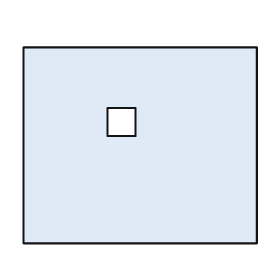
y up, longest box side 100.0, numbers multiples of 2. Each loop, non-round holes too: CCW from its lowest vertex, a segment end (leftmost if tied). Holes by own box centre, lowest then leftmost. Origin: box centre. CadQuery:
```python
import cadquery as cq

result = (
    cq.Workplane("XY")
    .moveTo(-50.0, -42.0)
    .lineTo(50.0, -42.0)
    .lineTo(50.0, 42.0)
    .lineTo(-50.0, 42.0)
    .close()
    .moveTo(-14.0, 4.0)
    .lineTo(-2.0, 4.0)
    .lineTo(-2.0, 16.0)
    .lineTo(-14.0, 16.0)
    .close()
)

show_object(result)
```